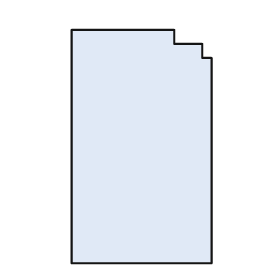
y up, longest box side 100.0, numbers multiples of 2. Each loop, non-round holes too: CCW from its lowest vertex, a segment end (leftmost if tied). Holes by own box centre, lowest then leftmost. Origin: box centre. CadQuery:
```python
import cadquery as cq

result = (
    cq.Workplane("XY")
    .moveTo(-30.0, -50.0)
    .lineTo(30.0, -50.0)
    .lineTo(30.0, 38.0)
    .lineTo(26.0, 38.0)
    .lineTo(26.0, 44.0)
    .lineTo(14.0, 44.0)
    .lineTo(14.0, 50.0)
    .lineTo(-30.0, 50.0)
    .close()
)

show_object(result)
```